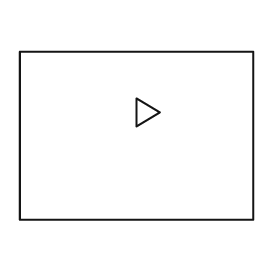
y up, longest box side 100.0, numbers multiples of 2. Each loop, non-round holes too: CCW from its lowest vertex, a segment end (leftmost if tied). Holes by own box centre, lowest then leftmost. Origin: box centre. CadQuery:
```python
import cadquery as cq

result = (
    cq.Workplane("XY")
    .moveTo(-50.0, -36.0)
    .lineTo(50.0, -36.0)
    .lineTo(50.0, 36.0)
    .lineTo(-50.0, 36.0)
    .close()
    .moveTo(0.0, 4.0)
    .lineTo(10.0, 10.0)
    .lineTo(0.0, 16.0)
    .close()
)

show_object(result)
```